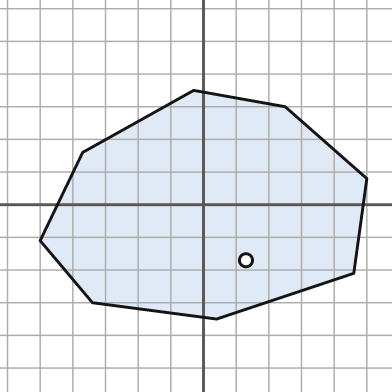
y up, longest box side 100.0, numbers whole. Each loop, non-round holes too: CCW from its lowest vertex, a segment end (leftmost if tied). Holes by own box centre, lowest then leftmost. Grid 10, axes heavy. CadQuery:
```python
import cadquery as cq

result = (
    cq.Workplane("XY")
    .moveTo(4.0, -35.0)
    .lineTo(46.0, -21.0)
    .lineTo(50.0, 8.0)
    .lineTo(25.0, 30.0)
    .lineTo(-3.0, 35.0)
    .lineTo(-37.0, 16.0)
    .lineTo(-50.0, -11.0)
    .lineTo(-34.0, -30.0)
    .close()
    .moveTo(13.0, -17.0)
    .circle(2.0)
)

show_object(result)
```